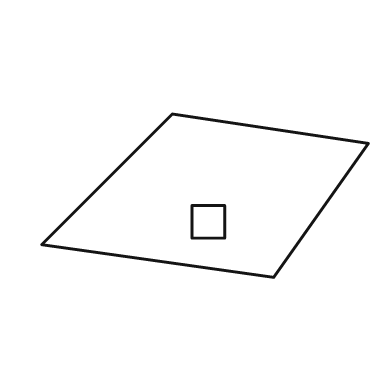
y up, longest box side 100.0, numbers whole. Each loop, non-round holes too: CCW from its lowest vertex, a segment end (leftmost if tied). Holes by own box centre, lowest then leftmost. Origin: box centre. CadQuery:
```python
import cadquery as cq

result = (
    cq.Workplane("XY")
    .moveTo(21.0, -25.0)
    .lineTo(50.0, 16.0)
    .lineTo(-10.0, 25.0)
    .lineTo(-50.0, -15.0)
    .close()
    .moveTo(-4.0, -13.0)
    .lineTo(6.0, -13.0)
    .lineTo(6.0, -3.0)
    .lineTo(-4.0, -3.0)
    .close()
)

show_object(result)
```